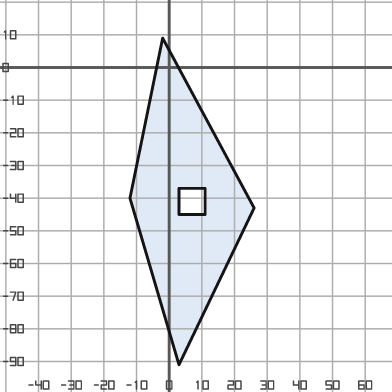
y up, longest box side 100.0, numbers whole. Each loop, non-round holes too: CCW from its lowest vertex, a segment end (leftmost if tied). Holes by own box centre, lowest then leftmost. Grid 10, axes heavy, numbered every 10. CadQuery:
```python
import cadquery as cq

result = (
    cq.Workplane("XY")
    .moveTo(3.0, -91.0)
    .lineTo(26.0, -43.0)
    .lineTo(-2.0, 9.0)
    .lineTo(-12.0, -40.0)
    .close()
    .moveTo(3.0, -45.0)
    .lineTo(11.0, -45.0)
    .lineTo(11.0, -37.0)
    .lineTo(3.0, -37.0)
    .close()
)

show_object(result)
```